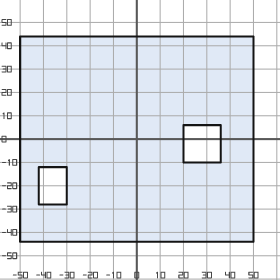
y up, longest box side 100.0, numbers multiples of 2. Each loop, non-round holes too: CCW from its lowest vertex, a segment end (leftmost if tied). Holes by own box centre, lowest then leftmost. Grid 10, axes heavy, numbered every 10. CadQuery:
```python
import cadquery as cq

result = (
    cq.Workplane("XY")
    .moveTo(-50.0, -44.0)
    .lineTo(50.0, -44.0)
    .lineTo(50.0, 44.0)
    .lineTo(-50.0, 44.0)
    .close()
    .moveTo(-42.0, -28.0)
    .lineTo(-30.0, -28.0)
    .lineTo(-30.0, -12.0)
    .lineTo(-42.0, -12.0)
    .close()
    .moveTo(20.0, -10.0)
    .lineTo(36.0, -10.0)
    .lineTo(36.0, 6.0)
    .lineTo(20.0, 6.0)
    .close()
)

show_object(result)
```